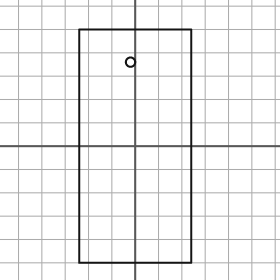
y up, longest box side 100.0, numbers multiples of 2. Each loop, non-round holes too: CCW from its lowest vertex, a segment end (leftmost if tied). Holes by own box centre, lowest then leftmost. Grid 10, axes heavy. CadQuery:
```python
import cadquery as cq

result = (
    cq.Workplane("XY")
    .moveTo(-24.0, -50.0)
    .lineTo(24.0, -50.0)
    .lineTo(24.0, 50.0)
    .lineTo(-24.0, 50.0)
    .close()
    .moveTo(-2.0, 36.0)
    .circle(2.0)
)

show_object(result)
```